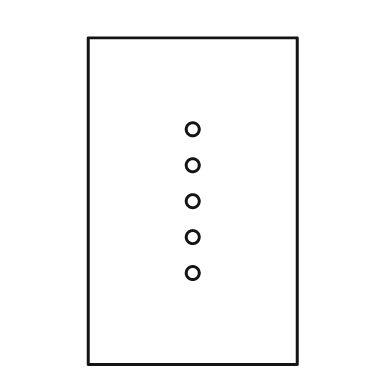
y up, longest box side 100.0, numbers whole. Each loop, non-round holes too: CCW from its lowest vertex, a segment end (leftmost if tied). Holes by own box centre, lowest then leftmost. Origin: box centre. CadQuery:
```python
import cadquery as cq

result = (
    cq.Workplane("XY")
    .moveTo(-32.0, -50.0)
    .lineTo(32.0, -50.0)
    .lineTo(32.0, 50.0)
    .lineTo(-32.0, 50.0)
    .close()
    .moveTo(0.0, -22.0)
    .circle(2.0)
    .moveTo(0.0, -11.0)
    .circle(2.0)
    .moveTo(0.0, 0.0)
    .circle(2.0)
    .moveTo(0.0, 11.0)
    .circle(2.0)
    .moveTo(0.0, 22.0)
    .circle(2.0)
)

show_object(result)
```